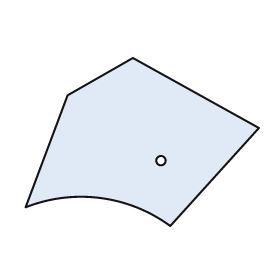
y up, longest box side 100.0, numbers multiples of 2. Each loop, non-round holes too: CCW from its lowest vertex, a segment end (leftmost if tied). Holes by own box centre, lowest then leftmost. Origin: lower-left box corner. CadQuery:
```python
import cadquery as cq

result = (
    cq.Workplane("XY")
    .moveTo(62.0, 0.0)
    .lineTo(100.0, 42.0)
    .lineTo(46.0, 72.0)
    .lineTo(18.0, 56.0)
    .lineTo(0.0, 8.0)
    .threePointArc((32.0, 12.0), (62.0, 0.0))
    .close()
    .moveTo(58.0, 28.0)
    .circle(2.0)
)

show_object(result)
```